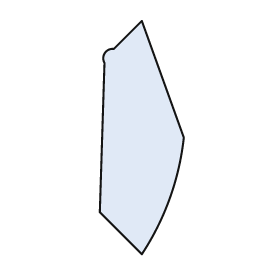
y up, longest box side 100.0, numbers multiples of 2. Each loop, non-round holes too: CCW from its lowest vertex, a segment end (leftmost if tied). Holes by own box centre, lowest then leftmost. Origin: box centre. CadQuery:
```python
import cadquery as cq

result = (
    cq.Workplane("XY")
    .moveTo(0.0, -50.0)
    .threePointArc((12.0, -26.0), (18.0, 0.0))
    .lineTo(0.0, 50.0)
    .lineTo(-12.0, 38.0)
    .threePointArc((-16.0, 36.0), (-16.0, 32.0))
    .lineTo(-18.0, -32.0)
    .close()
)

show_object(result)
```